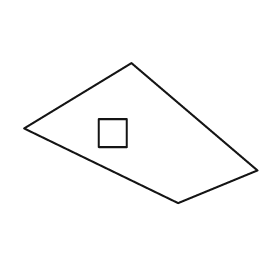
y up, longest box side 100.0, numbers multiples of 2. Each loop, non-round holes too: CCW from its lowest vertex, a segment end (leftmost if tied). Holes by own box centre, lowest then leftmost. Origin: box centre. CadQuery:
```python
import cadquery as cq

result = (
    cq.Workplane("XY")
    .moveTo(16.0, -30.0)
    .lineTo(50.0, -16.0)
    .lineTo(-4.0, 30.0)
    .lineTo(-50.0, 2.0)
    .close()
    .moveTo(-18.0, -6.0)
    .lineTo(-6.0, -6.0)
    .lineTo(-6.0, 6.0)
    .lineTo(-18.0, 6.0)
    .close()
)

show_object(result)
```